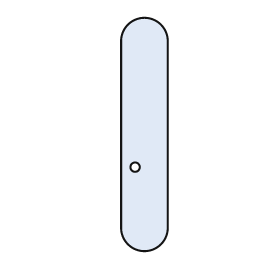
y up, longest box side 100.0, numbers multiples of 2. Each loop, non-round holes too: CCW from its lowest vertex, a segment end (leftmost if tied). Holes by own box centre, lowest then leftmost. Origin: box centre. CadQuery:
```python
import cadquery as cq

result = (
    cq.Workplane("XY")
    .moveTo(-10.0, -40.0)
    .threePointArc((0.0, -50.0), (10.0, -40.0))
    .lineTo(10.0, 40.0)
    .threePointArc((0.0, 50.0), (-10.0, 40.0))
    .close()
    .moveTo(-4.0, -14.0)
    .circle(2.0)
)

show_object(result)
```